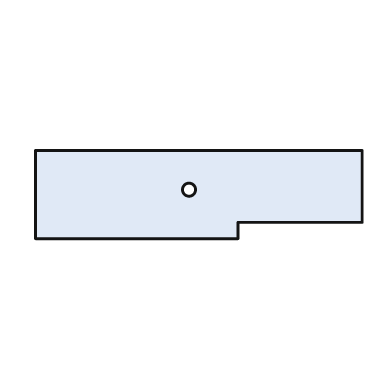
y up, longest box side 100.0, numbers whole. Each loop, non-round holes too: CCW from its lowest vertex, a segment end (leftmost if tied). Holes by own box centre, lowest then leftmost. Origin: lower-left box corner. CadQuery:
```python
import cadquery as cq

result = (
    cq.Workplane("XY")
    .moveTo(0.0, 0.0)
    .lineTo(62.0, 0.0)
    .lineTo(62.0, 5.0)
    .lineTo(100.0, 5.0)
    .lineTo(100.0, 27.0)
    .lineTo(0.0, 27.0)
    .close()
    .moveTo(47.0, 15.0)
    .circle(2.0)
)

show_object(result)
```